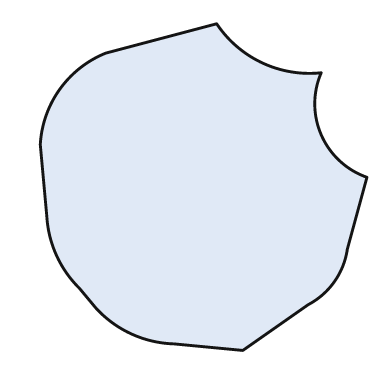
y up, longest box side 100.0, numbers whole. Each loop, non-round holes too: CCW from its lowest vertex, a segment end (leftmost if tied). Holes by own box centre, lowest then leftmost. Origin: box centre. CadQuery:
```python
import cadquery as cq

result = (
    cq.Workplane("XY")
    .moveTo(12.0, -50.0)
    .lineTo(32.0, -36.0)
    .threePointArc((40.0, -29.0), (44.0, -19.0))
    .lineTo(50.0, 3.0)
    .threePointArc((36.0, 16.0), (36.0, 35.0))
    .threePointArc((18.0, 38.0), (4.0, 50.0))
    .lineTo(-30.0, 41.0)
    .threePointArc((-44.0, 30.0), (-50.0, 13.0))
    .lineTo(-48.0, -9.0)
    .threePointArc((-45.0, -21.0), (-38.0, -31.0))
    .lineTo(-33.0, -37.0)
    .threePointArc((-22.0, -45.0), (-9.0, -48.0))
    .close()
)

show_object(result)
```